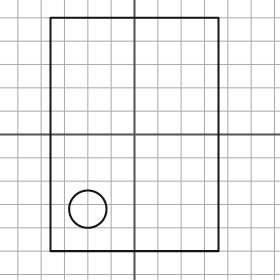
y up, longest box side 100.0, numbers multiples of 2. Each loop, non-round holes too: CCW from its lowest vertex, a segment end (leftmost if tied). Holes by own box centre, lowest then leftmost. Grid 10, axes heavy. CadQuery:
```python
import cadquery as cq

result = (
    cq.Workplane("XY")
    .moveTo(-36.0, -50.0)
    .lineTo(36.0, -50.0)
    .lineTo(36.0, 50.0)
    .lineTo(-36.0, 50.0)
    .close()
    .moveTo(-20.0, -32.0)
    .circle(8.0)
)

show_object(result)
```